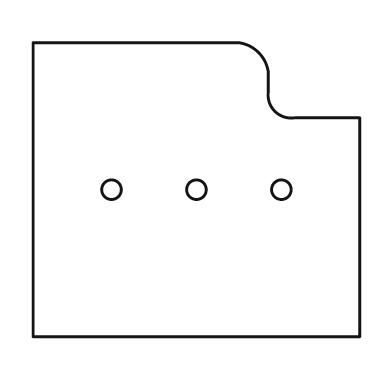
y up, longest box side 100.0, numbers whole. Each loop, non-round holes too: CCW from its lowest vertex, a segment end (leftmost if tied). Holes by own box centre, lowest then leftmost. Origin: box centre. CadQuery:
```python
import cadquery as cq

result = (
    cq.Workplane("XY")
    .moveTo(-50.0, -45.0)
    .lineTo(50.0, -45.0)
    .lineTo(50.0, 22.0)
    .lineTo(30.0, 22.0)
    .threePointArc((24.0, 24.0), (22.0, 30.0))
    .lineTo(22.0, 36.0)
    .threePointArc((19.0, 42.0), (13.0, 45.0))
    .lineTo(-50.0, 45.0)
    .close()
    .moveTo(-26.0, 0.0)
    .circle(3.0)
    .moveTo(0.0, 0.0)
    .circle(3.0)
    .moveTo(26.0, 0.0)
    .circle(3.0)
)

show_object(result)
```